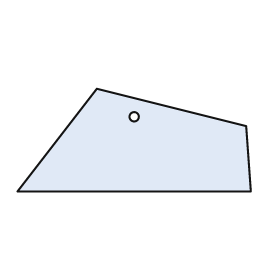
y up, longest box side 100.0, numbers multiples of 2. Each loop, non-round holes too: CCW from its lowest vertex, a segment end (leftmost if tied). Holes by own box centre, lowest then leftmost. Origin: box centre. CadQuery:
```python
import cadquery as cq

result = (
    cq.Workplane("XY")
    .moveTo(-50.0, -22.0)
    .lineTo(50.0, -22.0)
    .lineTo(48.0, 6.0)
    .lineTo(-16.0, 22.0)
    .close()
    .moveTo(0.0, 10.0)
    .circle(2.0)
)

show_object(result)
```